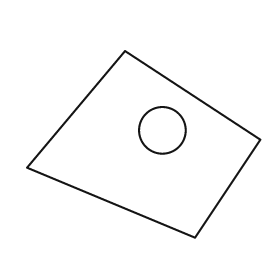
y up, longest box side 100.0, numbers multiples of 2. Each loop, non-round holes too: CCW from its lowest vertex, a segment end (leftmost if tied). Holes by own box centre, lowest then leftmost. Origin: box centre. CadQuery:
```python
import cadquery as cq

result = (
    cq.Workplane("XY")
    .moveTo(22.0, -40.0)
    .lineTo(50.0, 2.0)
    .lineTo(-8.0, 40.0)
    .lineTo(-50.0, -10.0)
    .close()
    .moveTo(8.0, 6.0)
    .circle(10.0)
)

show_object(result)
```